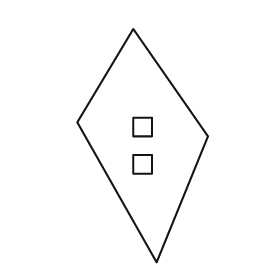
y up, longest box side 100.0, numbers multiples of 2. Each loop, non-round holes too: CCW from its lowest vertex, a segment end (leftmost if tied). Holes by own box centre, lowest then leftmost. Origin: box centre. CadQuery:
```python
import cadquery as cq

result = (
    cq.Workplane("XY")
    .moveTo(6.0, -50.0)
    .lineTo(28.0, 4.0)
    .lineTo(-4.0, 50.0)
    .lineTo(-28.0, 10.0)
    .close()
    .moveTo(-4.0, -12.0)
    .lineTo(4.0, -12.0)
    .lineTo(4.0, -4.0)
    .lineTo(-4.0, -4.0)
    .close()
    .moveTo(-4.0, 4.0)
    .lineTo(4.0, 4.0)
    .lineTo(4.0, 12.0)
    .lineTo(-4.0, 12.0)
    .close()
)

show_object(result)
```